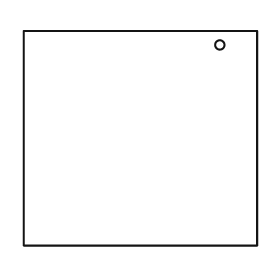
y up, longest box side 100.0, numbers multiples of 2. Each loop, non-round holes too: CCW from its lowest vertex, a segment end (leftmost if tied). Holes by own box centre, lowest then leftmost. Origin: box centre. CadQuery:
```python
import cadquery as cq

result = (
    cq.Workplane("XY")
    .moveTo(-50.0, -46.0)
    .lineTo(50.0, -46.0)
    .lineTo(50.0, 46.0)
    .lineTo(-50.0, 46.0)
    .close()
    .moveTo(34.0, 40.0)
    .circle(2.0)
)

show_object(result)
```